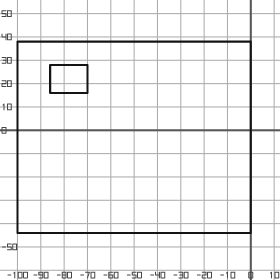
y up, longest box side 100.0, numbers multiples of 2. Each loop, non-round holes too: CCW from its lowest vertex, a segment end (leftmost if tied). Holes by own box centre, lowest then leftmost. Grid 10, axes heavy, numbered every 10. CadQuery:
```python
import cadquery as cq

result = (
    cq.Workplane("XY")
    .moveTo(-100.0, -44.0)
    .lineTo(0.0, -44.0)
    .lineTo(0.0, 38.0)
    .lineTo(-100.0, 38.0)
    .close()
    .moveTo(-86.0, 16.0)
    .lineTo(-70.0, 16.0)
    .lineTo(-70.0, 28.0)
    .lineTo(-86.0, 28.0)
    .close()
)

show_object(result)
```